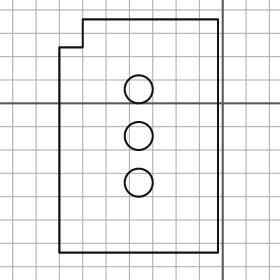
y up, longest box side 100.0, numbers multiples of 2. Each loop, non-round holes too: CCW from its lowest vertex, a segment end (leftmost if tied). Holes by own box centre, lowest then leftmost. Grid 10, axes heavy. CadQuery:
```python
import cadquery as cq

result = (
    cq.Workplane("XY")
    .moveTo(-70.0, -64.0)
    .lineTo(-2.0, -64.0)
    .lineTo(-2.0, 36.0)
    .lineTo(-60.0, 36.0)
    .lineTo(-60.0, 24.0)
    .lineTo(-70.0, 24.0)
    .close()
    .moveTo(-36.0, -34.0)
    .circle(6.0)
    .moveTo(-36.0, -14.0)
    .circle(6.0)
    .moveTo(-36.0, 6.0)
    .circle(6.0)
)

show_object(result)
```